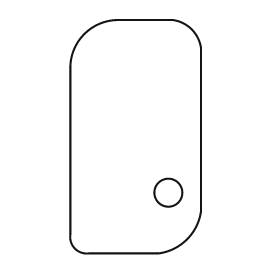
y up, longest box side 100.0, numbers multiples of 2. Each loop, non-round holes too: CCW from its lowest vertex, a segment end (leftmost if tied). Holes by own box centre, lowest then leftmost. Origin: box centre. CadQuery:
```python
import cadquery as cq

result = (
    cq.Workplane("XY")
    .moveTo(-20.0, -50.0)
    .lineTo(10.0, -50.0)
    .threePointArc((22.0, -44.0), (28.0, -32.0))
    .lineTo(28.0, 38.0)
    .threePointArc((24.0, 46.0), (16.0, 50.0))
    .lineTo(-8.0, 50.0)
    .threePointArc((-22.0, 44.0), (-28.0, 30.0))
    .lineTo(-28.0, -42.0)
    .threePointArc((-26.0, -48.0), (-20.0, -50.0))
    .close()
    .moveTo(14.0, -24.0)
    .circle(6.0)
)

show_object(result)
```